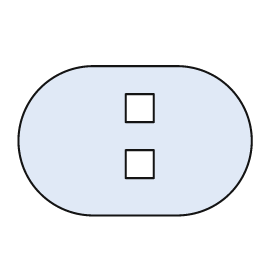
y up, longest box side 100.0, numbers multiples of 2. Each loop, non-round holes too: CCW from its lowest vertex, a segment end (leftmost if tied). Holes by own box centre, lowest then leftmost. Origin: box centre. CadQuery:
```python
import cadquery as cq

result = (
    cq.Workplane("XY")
    .moveTo(-18.0, -32.0)
    .lineTo(18.0, -32.0)
    .threePointArc((50.0, 0.0), (18.0, 32.0))
    .lineTo(-18.0, 32.0)
    .threePointArc((-50.0, 0.0), (-18.0, -32.0))
    .close()
    .moveTo(-4.0, -16.0)
    .lineTo(8.0, -16.0)
    .lineTo(8.0, -4.0)
    .lineTo(-4.0, -4.0)
    .close()
    .moveTo(-4.0, 8.0)
    .lineTo(8.0, 8.0)
    .lineTo(8.0, 20.0)
    .lineTo(-4.0, 20.0)
    .close()
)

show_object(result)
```